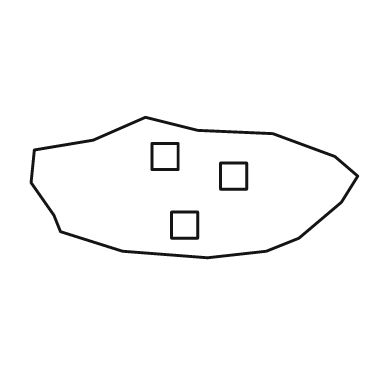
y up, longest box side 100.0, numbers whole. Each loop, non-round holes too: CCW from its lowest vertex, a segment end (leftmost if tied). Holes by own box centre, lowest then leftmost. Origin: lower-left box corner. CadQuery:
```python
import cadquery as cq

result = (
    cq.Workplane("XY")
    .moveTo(54.0, 0.0)
    .lineTo(72.0, 2.0)
    .lineTo(82.0, 6.0)
    .lineTo(95.0, 17.0)
    .lineTo(100.0, 25.0)
    .lineTo(93.0, 31.0)
    .lineTo(74.0, 38.0)
    .lineTo(51.0, 39.0)
    .lineTo(35.0, 43.0)
    .lineTo(19.0, 36.0)
    .lineTo(1.0, 33.0)
    .lineTo(0.0, 23.0)
    .lineTo(7.0, 13.0)
    .lineTo(9.0, 8.0)
    .lineTo(28.0, 2.0)
    .close()
    .moveTo(43.0, 6.0)
    .lineTo(51.0, 6.0)
    .lineTo(51.0, 14.0)
    .lineTo(43.0, 14.0)
    .close()
    .moveTo(58.0, 21.0)
    .lineTo(66.0, 21.0)
    .lineTo(66.0, 29.0)
    .lineTo(58.0, 29.0)
    .close()
    .moveTo(37.0, 27.0)
    .lineTo(45.0, 27.0)
    .lineTo(45.0, 35.0)
    .lineTo(37.0, 35.0)
    .close()
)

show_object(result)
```